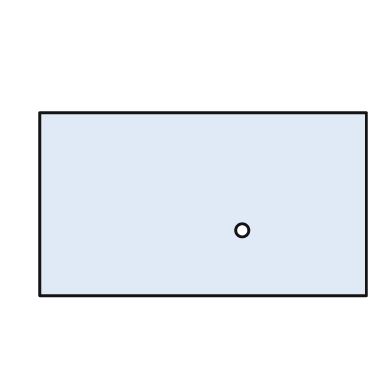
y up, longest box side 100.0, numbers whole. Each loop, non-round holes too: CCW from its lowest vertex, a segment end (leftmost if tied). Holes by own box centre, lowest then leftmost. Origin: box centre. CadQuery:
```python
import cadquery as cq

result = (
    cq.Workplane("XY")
    .moveTo(-50.0, -28.0)
    .lineTo(50.0, -28.0)
    .lineTo(50.0, 28.0)
    .lineTo(-50.0, 28.0)
    .close()
    .moveTo(12.0, -8.0)
    .circle(2.0)
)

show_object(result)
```